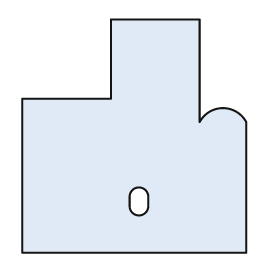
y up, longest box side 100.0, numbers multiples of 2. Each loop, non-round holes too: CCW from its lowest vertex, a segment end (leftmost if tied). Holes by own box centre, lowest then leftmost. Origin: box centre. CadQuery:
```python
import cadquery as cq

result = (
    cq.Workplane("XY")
    .moveTo(-48.0, -50.0)
    .lineTo(48.0, -50.0)
    .lineTo(48.0, 6.0)
    .threePointArc((38.0, 12.0), (28.0, 6.0))
    .lineTo(28.0, 50.0)
    .lineTo(-10.0, 50.0)
    .lineTo(-10.0, 16.0)
    .lineTo(-48.0, 16.0)
    .close()
    .moveTo(-2.0, -30.0)
    .threePointArc((2.0, -34.0), (6.0, -30.0))
    .lineTo(6.0, -26.0)
    .threePointArc((2.0, -22.0), (-2.0, -26.0))
    .close()
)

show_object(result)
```